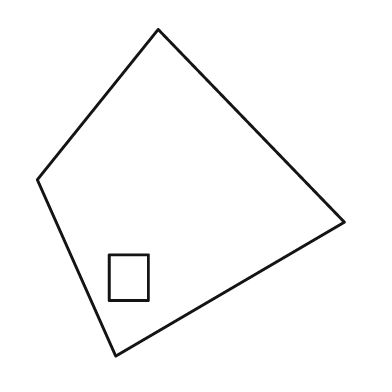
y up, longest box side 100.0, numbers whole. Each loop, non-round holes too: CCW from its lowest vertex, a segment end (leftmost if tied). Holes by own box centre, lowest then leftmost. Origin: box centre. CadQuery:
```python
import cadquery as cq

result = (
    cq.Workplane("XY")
    .moveTo(-23.0, -50.0)
    .lineTo(47.0, -9.0)
    .lineTo(-10.0, 50.0)
    .lineTo(-47.0, 4.0)
    .close()
    .moveTo(-25.0, -33.0)
    .lineTo(-13.0, -33.0)
    .lineTo(-13.0, -19.0)
    .lineTo(-25.0, -19.0)
    .close()
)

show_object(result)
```